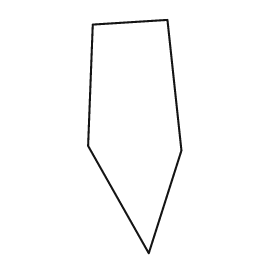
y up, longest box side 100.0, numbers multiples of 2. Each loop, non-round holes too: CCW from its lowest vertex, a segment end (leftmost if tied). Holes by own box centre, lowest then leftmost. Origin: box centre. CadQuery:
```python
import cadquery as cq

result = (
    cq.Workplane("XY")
    .moveTo(6.0, -50.0)
    .lineTo(20.0, -6.0)
    .lineTo(14.0, 50.0)
    .lineTo(-18.0, 48.0)
    .lineTo(-20.0, -4.0)
    .close()
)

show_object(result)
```